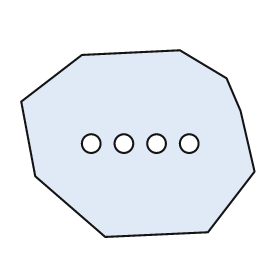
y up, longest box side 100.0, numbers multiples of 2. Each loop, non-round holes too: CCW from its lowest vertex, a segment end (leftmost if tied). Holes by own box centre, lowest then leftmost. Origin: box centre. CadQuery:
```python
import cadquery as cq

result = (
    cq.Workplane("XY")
    .moveTo(-14.0, -40.0)
    .lineTo(30.0, -38.0)
    .lineTo(50.0, -12.0)
    .lineTo(44.0, 14.0)
    .lineTo(38.0, 28.0)
    .lineTo(18.0, 40.0)
    .lineTo(-24.0, 38.0)
    .lineTo(-50.0, 18.0)
    .lineTo(-44.0, -14.0)
    .close()
    .moveTo(-20.0, 0.0)
    .circle(4.0)
    .moveTo(-6.0, 0.0)
    .circle(4.0)
    .moveTo(8.0, 0.0)
    .circle(4.0)
    .moveTo(22.0, 0.0)
    .circle(4.0)
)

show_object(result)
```